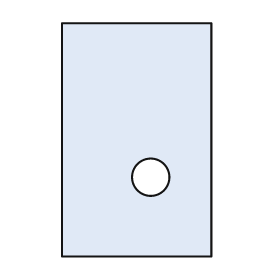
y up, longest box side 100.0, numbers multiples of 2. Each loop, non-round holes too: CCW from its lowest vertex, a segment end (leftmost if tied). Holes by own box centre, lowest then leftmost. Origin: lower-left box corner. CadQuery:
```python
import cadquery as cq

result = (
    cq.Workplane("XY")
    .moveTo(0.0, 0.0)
    .lineTo(64.0, 0.0)
    .lineTo(64.0, 100.0)
    .lineTo(0.0, 100.0)
    .close()
    .moveTo(38.0, 34.0)
    .circle(8.0)
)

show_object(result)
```